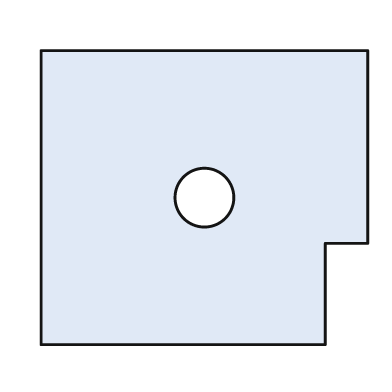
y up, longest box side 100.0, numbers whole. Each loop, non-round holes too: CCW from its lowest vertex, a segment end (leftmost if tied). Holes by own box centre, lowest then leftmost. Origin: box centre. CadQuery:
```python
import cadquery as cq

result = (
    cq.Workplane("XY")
    .moveTo(-50.0, -45.0)
    .lineTo(37.0, -45.0)
    .lineTo(37.0, -14.0)
    .lineTo(50.0, -14.0)
    .lineTo(50.0, 45.0)
    .lineTo(-50.0, 45.0)
    .close()
    .moveTo(0.0, 0.0)
    .circle(9.0)
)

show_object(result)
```